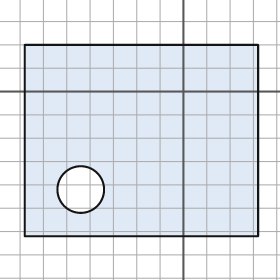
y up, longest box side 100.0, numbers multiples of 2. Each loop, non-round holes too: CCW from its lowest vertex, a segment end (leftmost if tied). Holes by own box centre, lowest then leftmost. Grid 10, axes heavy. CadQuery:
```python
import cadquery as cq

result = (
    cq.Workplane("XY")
    .moveTo(-68.0, -62.0)
    .lineTo(32.0, -62.0)
    .lineTo(32.0, 20.0)
    .lineTo(-68.0, 20.0)
    .close()
    .moveTo(-44.0, -42.0)
    .circle(10.0)
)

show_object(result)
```